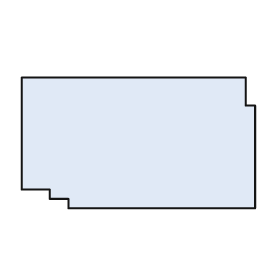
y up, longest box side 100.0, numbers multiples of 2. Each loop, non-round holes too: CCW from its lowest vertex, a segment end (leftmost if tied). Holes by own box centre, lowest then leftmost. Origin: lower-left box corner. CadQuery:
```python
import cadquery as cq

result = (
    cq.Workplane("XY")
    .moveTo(20.0, 0.0)
    .lineTo(100.0, 0.0)
    .lineTo(100.0, 44.0)
    .lineTo(96.0, 44.0)
    .lineTo(96.0, 56.0)
    .lineTo(0.0, 56.0)
    .lineTo(0.0, 8.0)
    .lineTo(12.0, 8.0)
    .lineTo(12.0, 4.0)
    .lineTo(20.0, 4.0)
    .close()
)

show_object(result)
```